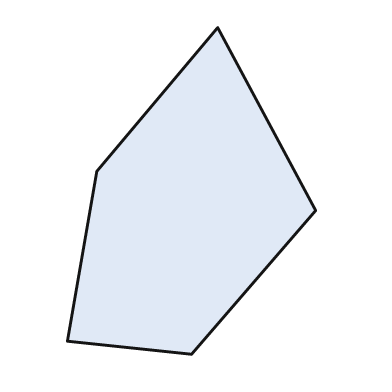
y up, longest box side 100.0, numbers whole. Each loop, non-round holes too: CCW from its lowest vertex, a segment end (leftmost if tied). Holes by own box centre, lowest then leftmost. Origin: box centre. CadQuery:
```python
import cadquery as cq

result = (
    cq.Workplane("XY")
    .moveTo(0.0, -50.0)
    .lineTo(38.0, -6.0)
    .lineTo(8.0, 50.0)
    .lineTo(-29.0, 6.0)
    .lineTo(-38.0, -46.0)
    .close()
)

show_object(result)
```